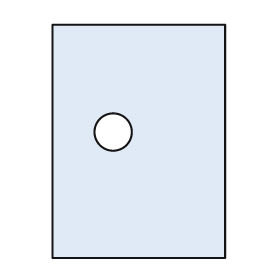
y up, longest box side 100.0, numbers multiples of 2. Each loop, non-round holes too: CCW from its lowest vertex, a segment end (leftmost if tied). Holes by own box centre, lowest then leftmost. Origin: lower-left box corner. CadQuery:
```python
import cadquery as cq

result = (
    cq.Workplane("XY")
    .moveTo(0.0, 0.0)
    .lineTo(74.0, 0.0)
    .lineTo(74.0, 100.0)
    .lineTo(0.0, 100.0)
    .close()
    .moveTo(26.0, 54.0)
    .circle(8.0)
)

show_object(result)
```